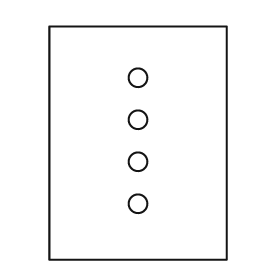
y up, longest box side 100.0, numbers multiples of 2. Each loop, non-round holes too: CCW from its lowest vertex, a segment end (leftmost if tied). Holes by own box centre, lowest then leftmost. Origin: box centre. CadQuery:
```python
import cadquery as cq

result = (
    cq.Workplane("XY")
    .moveTo(-38.0, -50.0)
    .lineTo(38.0, -50.0)
    .lineTo(38.0, 50.0)
    .lineTo(-38.0, 50.0)
    .close()
    .moveTo(0.0, -26.0)
    .circle(4.0)
    .moveTo(0.0, -8.0)
    .circle(4.0)
    .moveTo(0.0, 10.0)
    .circle(4.0)
    .moveTo(0.0, 28.0)
    .circle(4.0)
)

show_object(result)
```